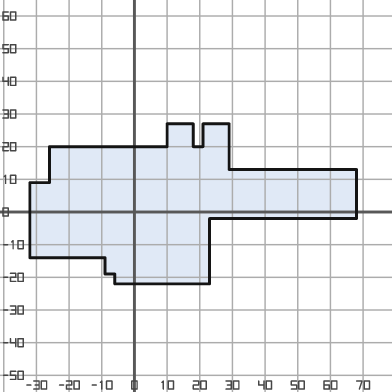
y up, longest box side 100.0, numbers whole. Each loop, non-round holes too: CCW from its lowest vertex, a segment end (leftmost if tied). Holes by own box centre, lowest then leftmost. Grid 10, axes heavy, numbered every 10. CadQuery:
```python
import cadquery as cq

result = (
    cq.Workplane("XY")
    .moveTo(-6.0, -22.0)
    .lineTo(23.0, -22.0)
    .lineTo(23.0, -2.0)
    .lineTo(68.0, -2.0)
    .lineTo(68.0, 13.0)
    .lineTo(29.0, 13.0)
    .lineTo(29.0, 27.0)
    .lineTo(21.0, 27.0)
    .lineTo(21.0, 20.0)
    .lineTo(18.0, 20.0)
    .lineTo(18.0, 27.0)
    .lineTo(10.0, 27.0)
    .lineTo(10.0, 20.0)
    .lineTo(-26.0, 20.0)
    .lineTo(-26.0, 9.0)
    .lineTo(-32.0, 9.0)
    .lineTo(-32.0, -14.0)
    .lineTo(-9.0, -14.0)
    .lineTo(-9.0, -19.0)
    .lineTo(-6.0, -19.0)
    .close()
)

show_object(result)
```